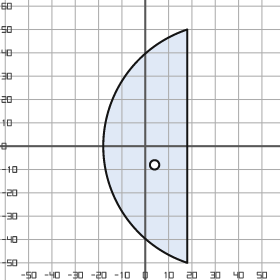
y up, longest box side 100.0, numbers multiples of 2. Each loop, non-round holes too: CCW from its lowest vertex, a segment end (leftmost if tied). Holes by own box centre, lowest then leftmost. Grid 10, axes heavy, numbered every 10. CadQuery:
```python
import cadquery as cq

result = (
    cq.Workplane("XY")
    .moveTo(18.0, -50.0)
    .lineTo(18.0, 50.0)
    .threePointArc((-18.0, 0.0), (18.0, -50.0))
    .close()
    .moveTo(4.0, -8.0)
    .circle(2.0)
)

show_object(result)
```